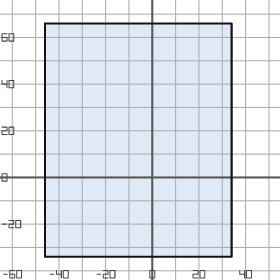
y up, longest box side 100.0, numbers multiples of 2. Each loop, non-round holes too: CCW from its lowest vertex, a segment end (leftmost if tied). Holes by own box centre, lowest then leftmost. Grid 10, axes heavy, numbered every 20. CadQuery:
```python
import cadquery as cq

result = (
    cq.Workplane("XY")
    .moveTo(-46.0, -34.0)
    .lineTo(34.0, -34.0)
    .lineTo(34.0, 66.0)
    .lineTo(-46.0, 66.0)
    .close()
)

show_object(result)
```